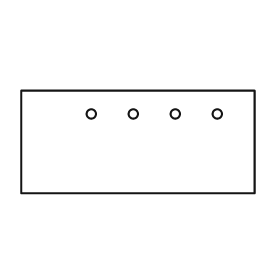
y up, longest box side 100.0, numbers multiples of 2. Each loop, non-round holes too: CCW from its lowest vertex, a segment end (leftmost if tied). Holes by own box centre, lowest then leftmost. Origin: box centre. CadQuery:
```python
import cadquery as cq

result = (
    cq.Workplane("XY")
    .moveTo(-50.0, -22.0)
    .lineTo(50.0, -22.0)
    .lineTo(50.0, 22.0)
    .lineTo(-50.0, 22.0)
    .close()
    .moveTo(-20.0, 12.0)
    .circle(2.0)
    .moveTo(-2.0, 12.0)
    .circle(2.0)
    .moveTo(16.0, 12.0)
    .circle(2.0)
    .moveTo(34.0, 12.0)
    .circle(2.0)
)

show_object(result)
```